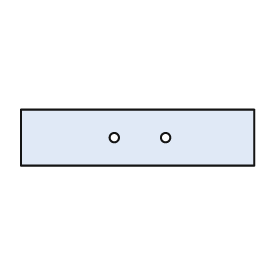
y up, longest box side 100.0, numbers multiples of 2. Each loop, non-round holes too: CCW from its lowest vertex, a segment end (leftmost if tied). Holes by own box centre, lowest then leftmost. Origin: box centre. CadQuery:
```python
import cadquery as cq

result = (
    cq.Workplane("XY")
    .moveTo(-50.0, -12.0)
    .lineTo(50.0, -12.0)
    .lineTo(50.0, 12.0)
    .lineTo(-50.0, 12.0)
    .close()
    .moveTo(-10.0, 0.0)
    .circle(2.0)
    .moveTo(12.0, 0.0)
    .circle(2.0)
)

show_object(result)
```